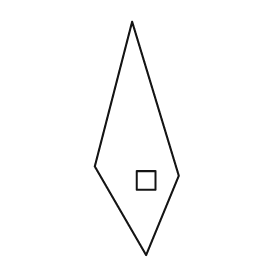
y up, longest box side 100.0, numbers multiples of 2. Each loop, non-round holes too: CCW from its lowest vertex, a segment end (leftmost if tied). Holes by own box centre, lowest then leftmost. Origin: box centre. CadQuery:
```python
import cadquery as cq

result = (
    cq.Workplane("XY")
    .moveTo(4.0, -50.0)
    .lineTo(18.0, -16.0)
    .lineTo(-2.0, 50.0)
    .lineTo(-18.0, -12.0)
    .close()
    .moveTo(0.0, -22.0)
    .lineTo(8.0, -22.0)
    .lineTo(8.0, -14.0)
    .lineTo(0.0, -14.0)
    .close()
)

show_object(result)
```